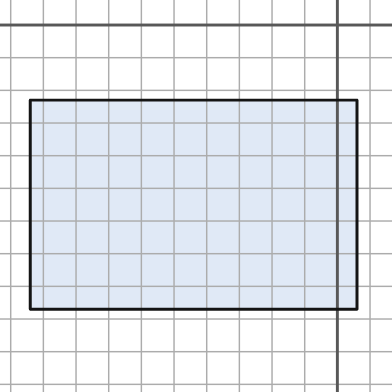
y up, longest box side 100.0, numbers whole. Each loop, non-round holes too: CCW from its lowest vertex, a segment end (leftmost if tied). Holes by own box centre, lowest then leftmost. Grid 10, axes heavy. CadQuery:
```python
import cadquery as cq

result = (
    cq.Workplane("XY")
    .moveTo(-94.0, -87.0)
    .lineTo(6.0, -87.0)
    .lineTo(6.0, -23.0)
    .lineTo(-94.0, -23.0)
    .close()
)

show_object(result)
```